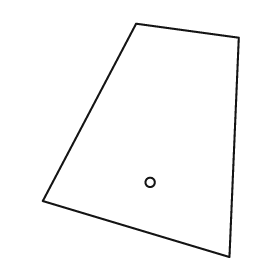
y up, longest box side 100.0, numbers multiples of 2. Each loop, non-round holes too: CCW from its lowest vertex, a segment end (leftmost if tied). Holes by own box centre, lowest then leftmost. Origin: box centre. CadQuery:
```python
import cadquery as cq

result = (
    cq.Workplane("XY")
    .moveTo(38.0, -50.0)
    .lineTo(42.0, 44.0)
    .lineTo(-2.0, 50.0)
    .lineTo(-42.0, -26.0)
    .close()
    .moveTo(4.0, -18.0)
    .circle(2.0)
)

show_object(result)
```